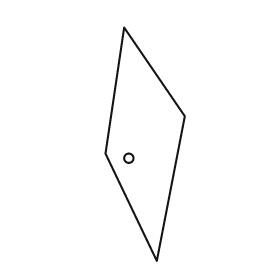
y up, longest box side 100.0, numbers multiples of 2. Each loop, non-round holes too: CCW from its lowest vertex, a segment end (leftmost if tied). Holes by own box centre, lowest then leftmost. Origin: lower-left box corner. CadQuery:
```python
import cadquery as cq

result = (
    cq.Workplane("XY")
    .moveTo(22.0, 0.0)
    .lineTo(34.0, 62.0)
    .lineTo(8.0, 100.0)
    .lineTo(0.0, 46.0)
    .close()
    .moveTo(10.0, 44.0)
    .circle(2.0)
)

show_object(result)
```